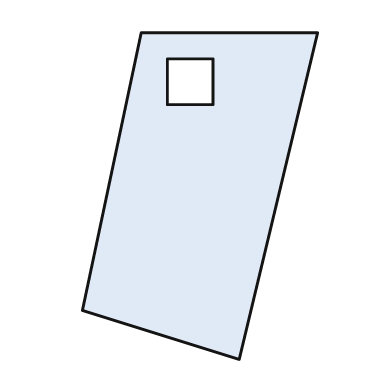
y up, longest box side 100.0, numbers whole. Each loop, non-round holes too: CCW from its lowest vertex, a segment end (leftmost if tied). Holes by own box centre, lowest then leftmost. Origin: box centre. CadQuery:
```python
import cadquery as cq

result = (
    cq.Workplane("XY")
    .moveTo(12.0, -50.0)
    .lineTo(36.0, 50.0)
    .lineTo(-18.0, 50.0)
    .lineTo(-36.0, -35.0)
    .close()
    .moveTo(-10.0, 28.0)
    .lineTo(4.0, 28.0)
    .lineTo(4.0, 42.0)
    .lineTo(-10.0, 42.0)
    .close()
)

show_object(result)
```